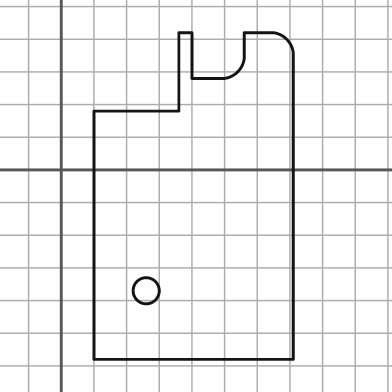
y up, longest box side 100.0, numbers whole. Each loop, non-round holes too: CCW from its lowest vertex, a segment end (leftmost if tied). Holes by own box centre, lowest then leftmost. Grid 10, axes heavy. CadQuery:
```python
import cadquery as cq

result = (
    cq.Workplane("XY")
    .moveTo(10.0, -58.0)
    .lineTo(71.0, -58.0)
    .lineTo(71.0, 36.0)
    .threePointArc((69.0, 40.0), (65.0, 42.0))
    .lineTo(56.0, 42.0)
    .lineTo(56.0, 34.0)
    .threePointArc((54.0, 30.0), (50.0, 28.0))
    .lineTo(40.0, 28.0)
    .lineTo(40.0, 42.0)
    .lineTo(36.0, 42.0)
    .lineTo(36.0, 18.0)
    .lineTo(10.0, 18.0)
    .close()
    .moveTo(26.0, -37.0)
    .circle(4.0)
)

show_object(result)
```